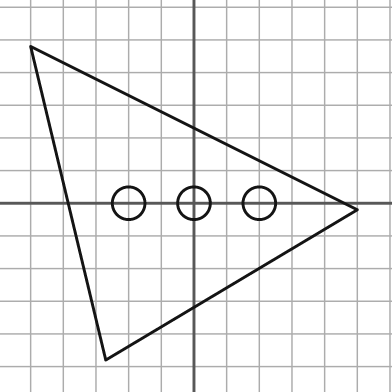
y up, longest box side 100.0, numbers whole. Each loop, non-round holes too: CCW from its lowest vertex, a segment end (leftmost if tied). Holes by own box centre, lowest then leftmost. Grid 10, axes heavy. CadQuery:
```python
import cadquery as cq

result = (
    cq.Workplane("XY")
    .moveTo(-27.0, -48.0)
    .lineTo(50.0, -2.0)
    .lineTo(-50.0, 48.0)
    .close()
    .moveTo(-20.0, 0.0)
    .circle(5.0)
    .moveTo(0.0, 0.0)
    .circle(5.0)
    .moveTo(20.0, 0.0)
    .circle(5.0)
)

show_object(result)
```